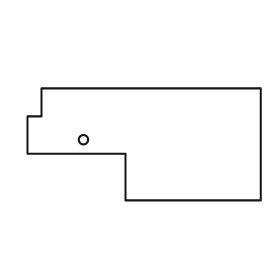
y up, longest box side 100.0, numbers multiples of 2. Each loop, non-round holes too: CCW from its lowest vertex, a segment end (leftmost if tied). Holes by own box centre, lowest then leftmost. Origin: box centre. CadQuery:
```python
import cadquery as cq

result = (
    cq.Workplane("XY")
    .moveTo(-8.0, -24.0)
    .lineTo(50.0, -24.0)
    .lineTo(50.0, 24.0)
    .lineTo(-44.0, 24.0)
    .lineTo(-44.0, 12.0)
    .lineTo(-50.0, 12.0)
    .lineTo(-50.0, -4.0)
    .lineTo(-8.0, -4.0)
    .close()
    .moveTo(-26.0, 2.0)
    .circle(2.0)
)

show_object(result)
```